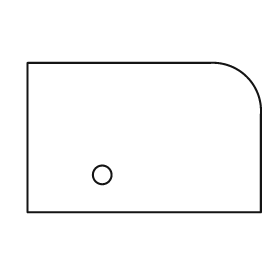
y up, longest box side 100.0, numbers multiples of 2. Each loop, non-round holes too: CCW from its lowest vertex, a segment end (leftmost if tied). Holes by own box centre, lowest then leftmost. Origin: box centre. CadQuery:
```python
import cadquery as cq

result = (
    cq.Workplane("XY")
    .moveTo(-50.0, -32.0)
    .lineTo(50.0, -32.0)
    .lineTo(50.0, 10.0)
    .threePointArc((44.0, 26.0), (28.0, 32.0))
    .lineTo(-50.0, 32.0)
    .close()
    .moveTo(-18.0, -16.0)
    .circle(4.0)
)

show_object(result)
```